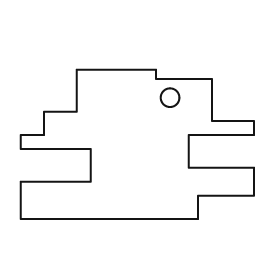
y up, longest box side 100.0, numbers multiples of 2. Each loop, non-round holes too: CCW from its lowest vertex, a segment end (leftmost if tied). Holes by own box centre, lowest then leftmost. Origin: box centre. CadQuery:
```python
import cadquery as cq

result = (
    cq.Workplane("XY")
    .moveTo(-50.0, -32.0)
    .lineTo(26.0, -32.0)
    .lineTo(26.0, -22.0)
    .lineTo(50.0, -22.0)
    .lineTo(50.0, -10.0)
    .lineTo(22.0, -10.0)
    .lineTo(22.0, 4.0)
    .lineTo(50.0, 4.0)
    .lineTo(50.0, 10.0)
    .lineTo(32.0, 10.0)
    .lineTo(32.0, 28.0)
    .lineTo(8.0, 28.0)
    .lineTo(8.0, 32.0)
    .lineTo(-26.0, 32.0)
    .lineTo(-26.0, 14.0)
    .lineTo(-40.0, 14.0)
    .lineTo(-40.0, 4.0)
    .lineTo(-50.0, 4.0)
    .lineTo(-50.0, -2.0)
    .lineTo(-20.0, -2.0)
    .lineTo(-20.0, -16.0)
    .lineTo(-50.0, -16.0)
    .close()
    .moveTo(14.0, 20.0)
    .circle(4.0)
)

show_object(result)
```